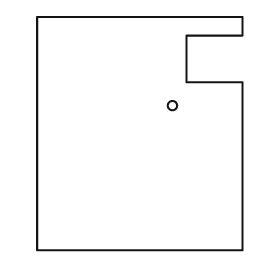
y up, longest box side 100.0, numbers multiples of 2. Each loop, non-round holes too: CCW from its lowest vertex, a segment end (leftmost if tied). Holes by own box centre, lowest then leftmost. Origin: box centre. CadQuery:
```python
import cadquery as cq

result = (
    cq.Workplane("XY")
    .moveTo(-44.0, -50.0)
    .lineTo(44.0, -50.0)
    .lineTo(44.0, 22.0)
    .lineTo(20.0, 22.0)
    .lineTo(20.0, 42.0)
    .lineTo(44.0, 42.0)
    .lineTo(44.0, 50.0)
    .lineTo(-44.0, 50.0)
    .close()
    .moveTo(14.0, 12.0)
    .circle(2.0)
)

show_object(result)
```